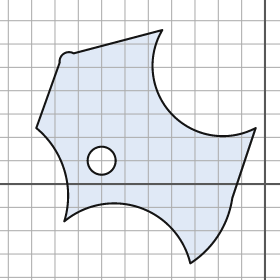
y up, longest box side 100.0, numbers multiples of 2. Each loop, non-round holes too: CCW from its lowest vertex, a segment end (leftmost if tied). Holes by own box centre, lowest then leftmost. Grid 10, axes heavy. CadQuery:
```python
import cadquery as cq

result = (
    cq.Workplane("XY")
    .moveTo(-32.0, -34.0)
    .threePointArc((-20.0, -22.0), (-14.0, -6.0))
    .lineTo(-4.0, 24.0)
    .threePointArc((-40.0, 30.0), (-44.0, 66.0))
    .lineTo(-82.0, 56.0)
    .threePointArc((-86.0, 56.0), (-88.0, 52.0))
    .lineTo(-98.0, 24.0)
    .threePointArc((-86.0, 6.0), (-86.0, -16.0))
    .threePointArc((-54.0, -10.0), (-32.0, -34.0))
    .close()
    .moveTo(-70.0, 10.0)
    .circle(6.0)
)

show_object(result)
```